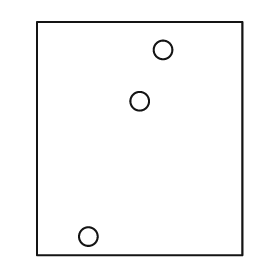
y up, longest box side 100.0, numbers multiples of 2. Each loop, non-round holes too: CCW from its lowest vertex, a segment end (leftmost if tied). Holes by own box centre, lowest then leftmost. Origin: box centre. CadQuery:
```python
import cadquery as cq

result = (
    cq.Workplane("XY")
    .moveTo(-44.0, -50.0)
    .lineTo(44.0, -50.0)
    .lineTo(44.0, 50.0)
    .lineTo(-44.0, 50.0)
    .close()
    .moveTo(-22.0, -42.0)
    .circle(4.0)
    .moveTo(0.0, 16.0)
    .circle(4.0)
    .moveTo(10.0, 38.0)
    .circle(4.0)
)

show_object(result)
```